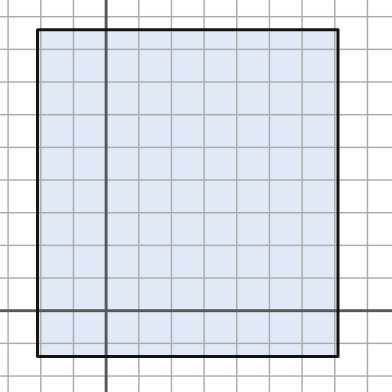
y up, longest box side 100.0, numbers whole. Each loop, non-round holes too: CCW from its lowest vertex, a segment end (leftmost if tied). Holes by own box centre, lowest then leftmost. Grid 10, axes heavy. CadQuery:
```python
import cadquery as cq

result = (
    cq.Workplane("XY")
    .moveTo(-21.0, -14.0)
    .lineTo(71.0, -14.0)
    .lineTo(71.0, 86.0)
    .lineTo(-21.0, 86.0)
    .close()
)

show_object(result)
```